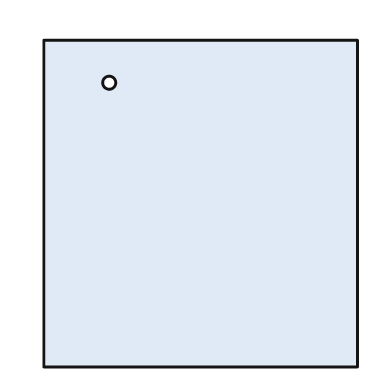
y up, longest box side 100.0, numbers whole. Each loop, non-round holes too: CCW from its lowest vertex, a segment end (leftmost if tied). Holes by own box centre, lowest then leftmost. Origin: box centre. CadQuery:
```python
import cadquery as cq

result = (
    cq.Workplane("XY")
    .moveTo(-48.0, -50.0)
    .lineTo(48.0, -50.0)
    .lineTo(48.0, 50.0)
    .lineTo(-48.0, 50.0)
    .close()
    .moveTo(-28.0, 37.0)
    .circle(2.0)
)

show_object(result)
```